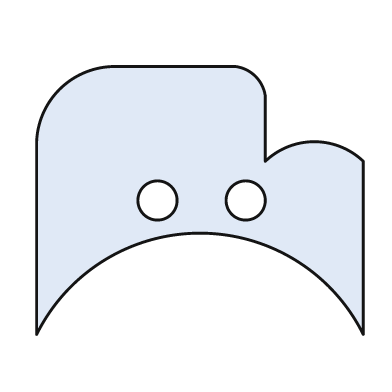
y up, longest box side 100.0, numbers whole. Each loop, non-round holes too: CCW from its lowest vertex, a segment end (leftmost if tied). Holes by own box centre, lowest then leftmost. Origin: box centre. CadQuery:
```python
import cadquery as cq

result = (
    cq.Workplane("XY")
    .moveTo(-50.0, -41.0)
    .threePointArc((0.0, -10.0), (50.0, -41.0))
    .lineTo(50.0, 12.0)
    .threePointArc((35.0, 18.0), (20.0, 12.0))
    .lineTo(20.0, 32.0)
    .threePointArc((17.0, 38.0), (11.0, 41.0))
    .lineTo(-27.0, 41.0)
    .threePointArc((-43.0, 34.0), (-50.0, 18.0))
    .close()
    .moveTo(-13.0, 0.0)
    .circle(6.0)
    .moveTo(14.0, 0.0)
    .circle(6.0)
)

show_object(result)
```